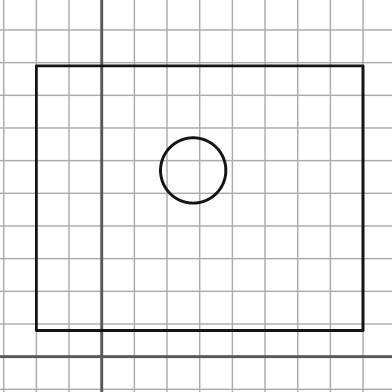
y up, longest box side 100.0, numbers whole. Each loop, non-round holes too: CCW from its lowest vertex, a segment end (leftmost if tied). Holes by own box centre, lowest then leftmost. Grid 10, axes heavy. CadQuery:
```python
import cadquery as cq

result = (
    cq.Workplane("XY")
    .moveTo(-20.0, 8.0)
    .lineTo(80.0, 8.0)
    .lineTo(80.0, 89.0)
    .lineTo(-20.0, 89.0)
    .close()
    .moveTo(28.0, 57.0)
    .circle(10.0)
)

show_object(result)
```